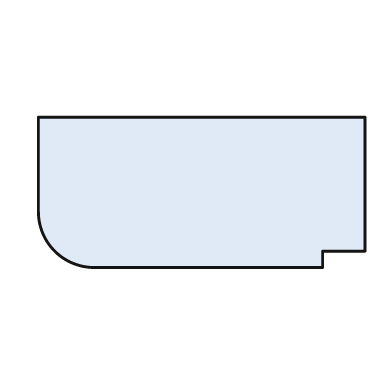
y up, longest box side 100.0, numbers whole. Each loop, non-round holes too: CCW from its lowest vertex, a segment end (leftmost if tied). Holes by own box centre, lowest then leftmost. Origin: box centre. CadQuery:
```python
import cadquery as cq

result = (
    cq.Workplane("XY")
    .moveTo(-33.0, -23.0)
    .lineTo(37.0, -23.0)
    .lineTo(37.0, -18.0)
    .lineTo(50.0, -18.0)
    .lineTo(50.0, 23.0)
    .lineTo(-50.0, 23.0)
    .lineTo(-50.0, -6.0)
    .threePointArc((-45.0, -18.0), (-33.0, -23.0))
    .close()
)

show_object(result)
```